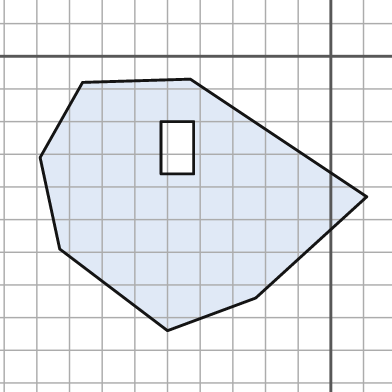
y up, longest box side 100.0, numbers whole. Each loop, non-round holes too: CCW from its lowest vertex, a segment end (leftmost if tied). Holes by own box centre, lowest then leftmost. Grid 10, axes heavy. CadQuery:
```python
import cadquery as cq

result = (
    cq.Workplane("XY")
    .moveTo(-50.0, -84.0)
    .lineTo(-23.0, -74.0)
    .lineTo(11.0, -43.0)
    .lineTo(-43.0, -7.0)
    .lineTo(-76.0, -8.0)
    .lineTo(-89.0, -31.0)
    .lineTo(-83.0, -59.0)
    .close()
    .moveTo(-52.0, -36.0)
    .lineTo(-42.0, -36.0)
    .lineTo(-42.0, -20.0)
    .lineTo(-52.0, -20.0)
    .close()
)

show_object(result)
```